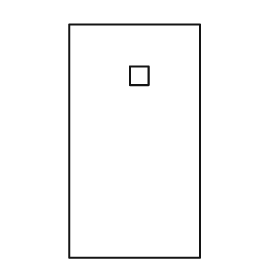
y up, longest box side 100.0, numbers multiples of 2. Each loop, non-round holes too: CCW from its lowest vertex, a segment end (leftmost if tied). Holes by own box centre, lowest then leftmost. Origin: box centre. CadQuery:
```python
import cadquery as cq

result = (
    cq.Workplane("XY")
    .moveTo(-28.0, -50.0)
    .lineTo(28.0, -50.0)
    .lineTo(28.0, 50.0)
    .lineTo(-28.0, 50.0)
    .close()
    .moveTo(-2.0, 24.0)
    .lineTo(6.0, 24.0)
    .lineTo(6.0, 32.0)
    .lineTo(-2.0, 32.0)
    .close()
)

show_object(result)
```